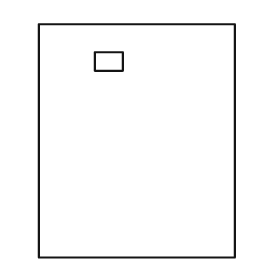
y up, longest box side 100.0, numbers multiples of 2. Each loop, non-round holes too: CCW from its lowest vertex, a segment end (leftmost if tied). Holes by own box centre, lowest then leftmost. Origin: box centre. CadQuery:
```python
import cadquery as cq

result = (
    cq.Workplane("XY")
    .moveTo(-42.0, -50.0)
    .lineTo(42.0, -50.0)
    .lineTo(42.0, 50.0)
    .lineTo(-42.0, 50.0)
    .close()
    .moveTo(-18.0, 30.0)
    .lineTo(-6.0, 30.0)
    .lineTo(-6.0, 38.0)
    .lineTo(-18.0, 38.0)
    .close()
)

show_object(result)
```